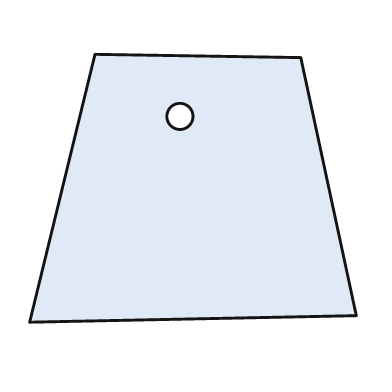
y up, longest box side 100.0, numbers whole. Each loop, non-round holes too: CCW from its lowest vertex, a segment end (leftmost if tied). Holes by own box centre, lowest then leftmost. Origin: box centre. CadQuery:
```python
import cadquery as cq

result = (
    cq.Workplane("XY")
    .moveTo(-50.0, -41.0)
    .lineTo(50.0, -39.0)
    .lineTo(33.0, 40.0)
    .lineTo(-30.0, 41.0)
    .close()
    .moveTo(-4.0, 22.0)
    .circle(4.0)
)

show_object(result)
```